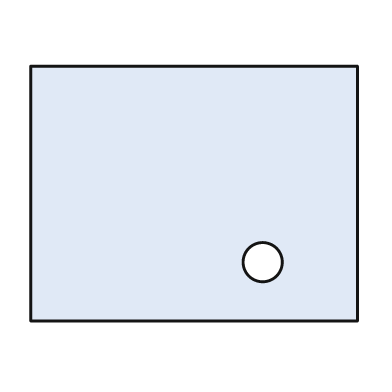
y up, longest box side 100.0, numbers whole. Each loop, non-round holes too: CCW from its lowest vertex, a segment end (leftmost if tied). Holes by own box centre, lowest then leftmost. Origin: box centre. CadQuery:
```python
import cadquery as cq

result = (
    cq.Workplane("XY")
    .moveTo(-50.0, -39.0)
    .lineTo(50.0, -39.0)
    .lineTo(50.0, 39.0)
    .lineTo(-50.0, 39.0)
    .close()
    .moveTo(21.0, -21.0)
    .circle(6.0)
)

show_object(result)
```